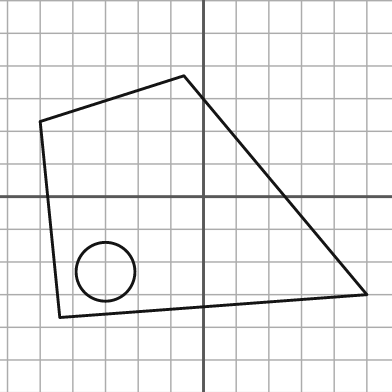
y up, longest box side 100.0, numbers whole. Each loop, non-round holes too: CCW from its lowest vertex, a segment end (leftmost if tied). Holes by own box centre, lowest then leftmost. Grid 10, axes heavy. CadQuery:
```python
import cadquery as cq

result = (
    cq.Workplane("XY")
    .moveTo(-44.0, -37.0)
    .lineTo(50.0, -30.0)
    .lineTo(-6.0, 37.0)
    .lineTo(-50.0, 23.0)
    .close()
    .moveTo(-30.0, -23.0)
    .circle(9.0)
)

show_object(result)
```